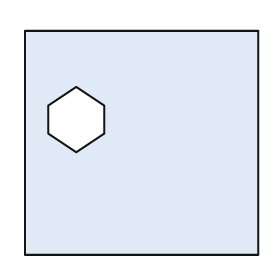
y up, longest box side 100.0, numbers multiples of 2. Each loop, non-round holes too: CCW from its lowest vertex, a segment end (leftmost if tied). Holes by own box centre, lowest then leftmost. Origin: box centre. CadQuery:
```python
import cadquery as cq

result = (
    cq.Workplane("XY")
    .moveTo(-50.0, -48.0)
    .lineTo(50.0, -48.0)
    .lineTo(50.0, 48.0)
    .lineTo(-50.0, 48.0)
    .close()
    .moveTo(-28.0, -4.0)
    .lineTo(-16.0, 4.0)
    .lineTo(-16.0, 16.0)
    .lineTo(-28.0, 24.0)
    .lineTo(-40.0, 16.0)
    .lineTo(-40.0, 4.0)
    .close()
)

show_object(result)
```